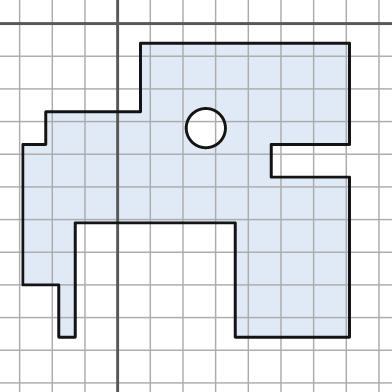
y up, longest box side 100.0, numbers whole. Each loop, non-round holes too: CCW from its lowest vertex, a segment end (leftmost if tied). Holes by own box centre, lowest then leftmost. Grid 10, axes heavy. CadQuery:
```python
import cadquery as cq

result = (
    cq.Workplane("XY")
    .moveTo(-18.0, -96.0)
    .lineTo(-13.0, -96.0)
    .lineTo(-13.0, -61.0)
    .lineTo(36.0, -61.0)
    .lineTo(36.0, -96.0)
    .lineTo(71.0, -96.0)
    .lineTo(71.0, -47.0)
    .lineTo(47.0, -47.0)
    .lineTo(47.0, -37.0)
    .lineTo(71.0, -37.0)
    .lineTo(71.0, -6.0)
    .lineTo(7.0, -6.0)
    .lineTo(7.0, -27.0)
    .lineTo(-22.0, -27.0)
    .lineTo(-22.0, -37.0)
    .lineTo(-29.0, -37.0)
    .lineTo(-29.0, -80.0)
    .lineTo(-18.0, -80.0)
    .close()
    .moveTo(27.0, -32.0)
    .circle(6.0)
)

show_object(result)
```